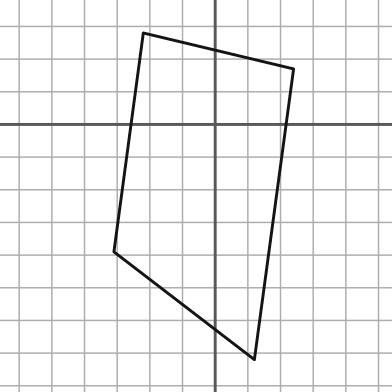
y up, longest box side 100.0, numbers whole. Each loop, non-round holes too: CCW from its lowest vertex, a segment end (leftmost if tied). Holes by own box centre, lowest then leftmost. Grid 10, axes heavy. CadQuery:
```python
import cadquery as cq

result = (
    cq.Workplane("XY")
    .moveTo(12.0, -72.0)
    .lineTo(24.0, 17.0)
    .lineTo(-22.0, 28.0)
    .lineTo(-31.0, -39.0)
    .close()
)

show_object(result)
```